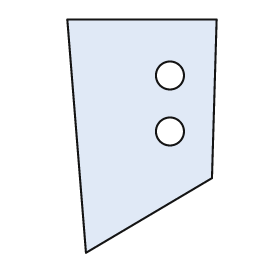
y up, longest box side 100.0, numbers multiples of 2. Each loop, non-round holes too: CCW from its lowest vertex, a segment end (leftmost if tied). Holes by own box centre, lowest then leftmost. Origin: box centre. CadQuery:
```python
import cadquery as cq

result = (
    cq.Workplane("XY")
    .moveTo(-24.0, -50.0)
    .lineTo(30.0, -18.0)
    .lineTo(32.0, 50.0)
    .lineTo(-32.0, 50.0)
    .close()
    .moveTo(12.0, 2.0)
    .circle(6.0)
    .moveTo(12.0, 26.0)
    .circle(6.0)
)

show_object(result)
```